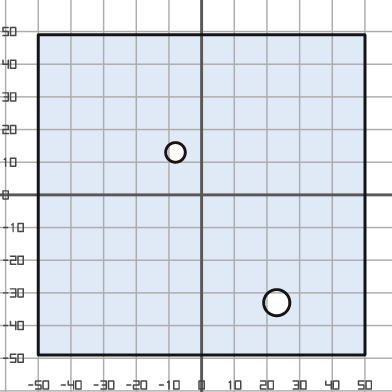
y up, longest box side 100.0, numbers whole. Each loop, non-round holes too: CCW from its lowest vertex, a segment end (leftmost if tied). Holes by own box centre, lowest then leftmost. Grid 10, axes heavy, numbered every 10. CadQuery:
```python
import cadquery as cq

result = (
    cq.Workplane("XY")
    .moveTo(-50.0, -49.0)
    .lineTo(50.0, -49.0)
    .lineTo(50.0, 49.0)
    .lineTo(-50.0, 49.0)
    .close()
    .moveTo(23.0, -33.0)
    .circle(4.0)
    .moveTo(-8.0, 13.0)
    .circle(3.0)
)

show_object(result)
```